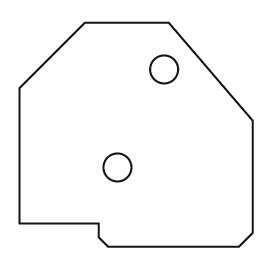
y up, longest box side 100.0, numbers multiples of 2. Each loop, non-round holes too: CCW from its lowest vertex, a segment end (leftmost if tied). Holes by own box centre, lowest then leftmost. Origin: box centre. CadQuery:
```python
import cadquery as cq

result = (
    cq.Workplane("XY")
    .moveTo(-12.0, -48.0)
    .lineTo(44.0, -48.0)
    .lineTo(50.0, -42.0)
    .lineTo(50.0, 6.0)
    .lineTo(14.0, 48.0)
    .lineTo(-22.0, 48.0)
    .lineTo(-50.0, 20.0)
    .lineTo(-50.0, -38.0)
    .lineTo(-16.0, -38.0)
    .lineTo(-16.0, -44.0)
    .close()
    .moveTo(-8.0, -14.0)
    .circle(6.0)
    .moveTo(12.0, 28.0)
    .circle(6.0)
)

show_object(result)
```